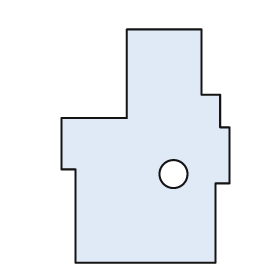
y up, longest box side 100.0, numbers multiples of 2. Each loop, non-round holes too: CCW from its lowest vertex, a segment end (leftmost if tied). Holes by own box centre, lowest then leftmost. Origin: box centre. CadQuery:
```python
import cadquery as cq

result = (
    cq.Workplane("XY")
    .moveTo(-30.0, -50.0)
    .lineTo(30.0, -50.0)
    .lineTo(30.0, -16.0)
    .lineTo(36.0, -16.0)
    .lineTo(36.0, 8.0)
    .lineTo(32.0, 8.0)
    .lineTo(32.0, 22.0)
    .lineTo(24.0, 22.0)
    .lineTo(24.0, 50.0)
    .lineTo(-8.0, 50.0)
    .lineTo(-8.0, 12.0)
    .lineTo(-36.0, 12.0)
    .lineTo(-36.0, -10.0)
    .lineTo(-30.0, -10.0)
    .close()
    .moveTo(12.0, -12.0)
    .circle(6.0)
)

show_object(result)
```